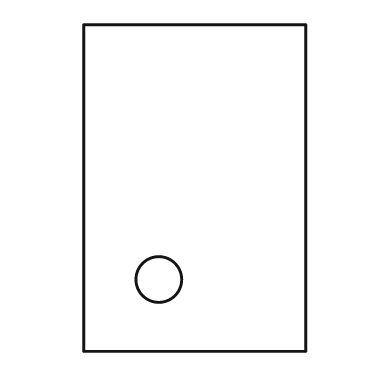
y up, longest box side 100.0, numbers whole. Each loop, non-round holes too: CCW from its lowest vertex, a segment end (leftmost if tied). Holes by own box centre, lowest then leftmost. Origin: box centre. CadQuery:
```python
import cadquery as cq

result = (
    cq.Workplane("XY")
    .moveTo(-34.0, -50.0)
    .lineTo(34.0, -50.0)
    .lineTo(34.0, 50.0)
    .lineTo(-34.0, 50.0)
    .close()
    .moveTo(-11.0, -28.0)
    .circle(7.0)
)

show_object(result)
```